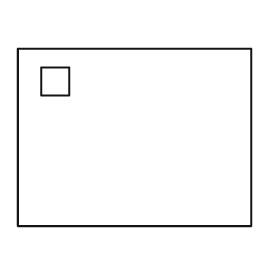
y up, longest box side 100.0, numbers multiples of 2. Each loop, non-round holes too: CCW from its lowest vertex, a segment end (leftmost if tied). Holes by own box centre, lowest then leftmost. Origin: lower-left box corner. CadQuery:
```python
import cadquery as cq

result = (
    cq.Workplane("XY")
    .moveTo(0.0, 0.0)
    .lineTo(100.0, 0.0)
    .lineTo(100.0, 76.0)
    .lineTo(0.0, 76.0)
    .close()
    .moveTo(10.0, 56.0)
    .lineTo(22.0, 56.0)
    .lineTo(22.0, 68.0)
    .lineTo(10.0, 68.0)
    .close()
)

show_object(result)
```